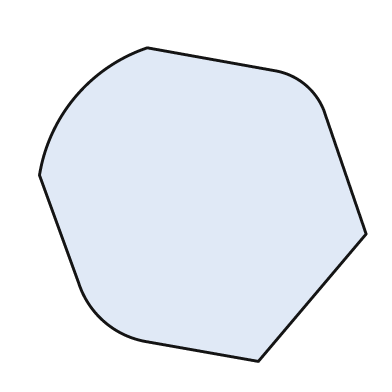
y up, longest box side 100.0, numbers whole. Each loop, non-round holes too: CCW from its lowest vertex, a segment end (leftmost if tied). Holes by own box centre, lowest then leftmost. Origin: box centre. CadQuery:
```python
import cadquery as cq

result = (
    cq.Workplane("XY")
    .moveTo(17.0, -48.0)
    .lineTo(50.0, -9.0)
    .lineTo(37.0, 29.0)
    .threePointArc((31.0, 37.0), (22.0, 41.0))
    .lineTo(-17.0, 48.0)
    .threePointArc((-39.0, 33.0), (-50.0, 9.0))
    .lineTo(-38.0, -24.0)
    .threePointArc((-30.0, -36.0), (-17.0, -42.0))
    .close()
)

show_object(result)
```